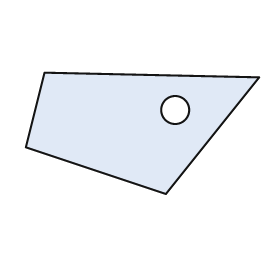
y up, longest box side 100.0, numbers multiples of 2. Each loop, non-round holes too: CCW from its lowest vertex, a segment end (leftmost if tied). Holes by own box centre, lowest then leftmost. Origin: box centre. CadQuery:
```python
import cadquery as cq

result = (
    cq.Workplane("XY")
    .moveTo(10.0, -26.0)
    .lineTo(50.0, 24.0)
    .lineTo(-42.0, 26.0)
    .lineTo(-50.0, -6.0)
    .close()
    .moveTo(14.0, 10.0)
    .circle(6.0)
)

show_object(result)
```